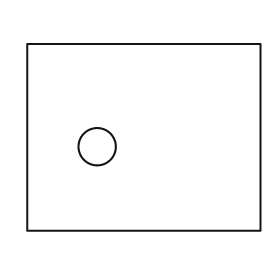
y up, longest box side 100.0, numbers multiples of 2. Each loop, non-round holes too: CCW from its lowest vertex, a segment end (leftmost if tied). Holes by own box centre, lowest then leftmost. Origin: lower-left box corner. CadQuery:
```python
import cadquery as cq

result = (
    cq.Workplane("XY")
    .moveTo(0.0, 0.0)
    .lineTo(100.0, 0.0)
    .lineTo(100.0, 80.0)
    .lineTo(0.0, 80.0)
    .close()
    .moveTo(30.0, 36.0)
    .circle(8.0)
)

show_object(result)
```